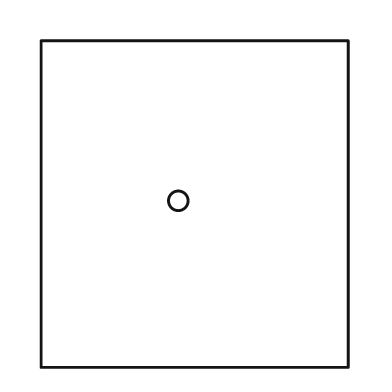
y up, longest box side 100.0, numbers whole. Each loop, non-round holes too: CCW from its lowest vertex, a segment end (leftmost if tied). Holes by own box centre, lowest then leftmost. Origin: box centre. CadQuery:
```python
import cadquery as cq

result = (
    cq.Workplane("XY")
    .moveTo(-47.0, -50.0)
    .lineTo(47.0, -50.0)
    .lineTo(47.0, 50.0)
    .lineTo(-47.0, 50.0)
    .close()
    .moveTo(-5.0, 1.0)
    .circle(3.0)
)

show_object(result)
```